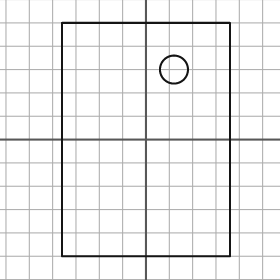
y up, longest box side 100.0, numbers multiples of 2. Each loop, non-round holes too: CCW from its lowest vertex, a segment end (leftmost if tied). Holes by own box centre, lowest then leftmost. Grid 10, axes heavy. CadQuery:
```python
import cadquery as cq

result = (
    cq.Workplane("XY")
    .moveTo(-36.0, -50.0)
    .lineTo(36.0, -50.0)
    .lineTo(36.0, 50.0)
    .lineTo(-36.0, 50.0)
    .close()
    .moveTo(12.0, 30.0)
    .circle(6.0)
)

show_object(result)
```